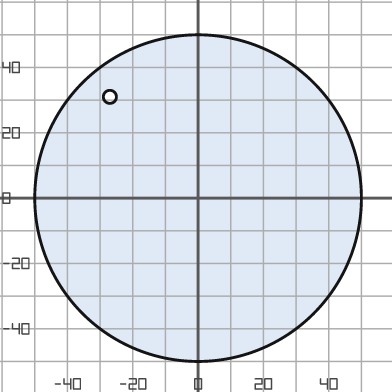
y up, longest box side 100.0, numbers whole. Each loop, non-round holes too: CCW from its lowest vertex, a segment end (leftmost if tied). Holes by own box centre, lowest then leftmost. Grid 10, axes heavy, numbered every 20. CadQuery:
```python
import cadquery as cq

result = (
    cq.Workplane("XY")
    .moveTo(0.0, 0.0)
    .circle(50.0)
    .moveTo(-27.0, 31.0)
    .circle(2.0)
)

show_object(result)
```